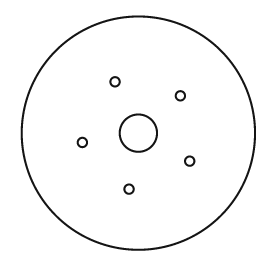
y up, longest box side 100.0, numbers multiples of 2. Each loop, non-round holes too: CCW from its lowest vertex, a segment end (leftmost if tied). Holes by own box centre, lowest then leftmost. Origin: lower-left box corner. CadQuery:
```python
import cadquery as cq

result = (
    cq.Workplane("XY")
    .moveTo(50.0, 50.0)
    .circle(50.0)
    .moveTo(46.0, 26.0)
    .circle(2.0)
    .moveTo(72.0, 38.0)
    .circle(2.0)
    .moveTo(26.0, 46.0)
    .circle(2.0)
    .moveTo(50.0, 50.0)
    .circle(8.0)
    .moveTo(68.0, 66.0)
    .circle(2.0)
    .moveTo(40.0, 72.0)
    .circle(2.0)
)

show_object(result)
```